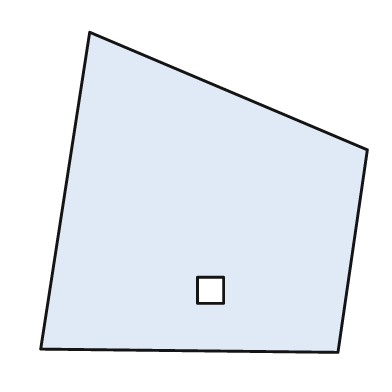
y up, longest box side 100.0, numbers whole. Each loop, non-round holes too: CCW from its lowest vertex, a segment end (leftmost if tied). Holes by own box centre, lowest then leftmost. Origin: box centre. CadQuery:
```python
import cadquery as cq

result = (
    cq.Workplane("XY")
    .moveTo(41.0, -49.0)
    .lineTo(50.0, 13.0)
    .lineTo(-35.0, 49.0)
    .lineTo(-50.0, -48.0)
    .close()
    .moveTo(-2.0, -34.0)
    .lineTo(6.0, -34.0)
    .lineTo(6.0, -26.0)
    .lineTo(-2.0, -26.0)
    .close()
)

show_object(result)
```